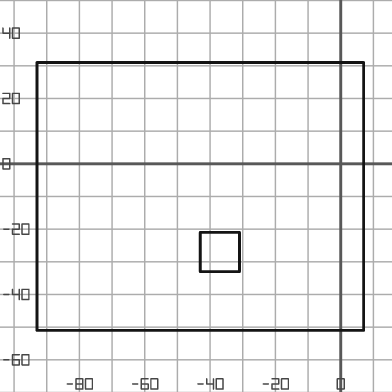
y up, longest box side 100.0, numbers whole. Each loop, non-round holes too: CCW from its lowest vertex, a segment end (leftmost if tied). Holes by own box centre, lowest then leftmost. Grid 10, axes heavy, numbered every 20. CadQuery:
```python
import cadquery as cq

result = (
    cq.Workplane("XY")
    .moveTo(-93.0, -51.0)
    .lineTo(7.0, -51.0)
    .lineTo(7.0, 31.0)
    .lineTo(-93.0, 31.0)
    .close()
    .moveTo(-43.0, -33.0)
    .lineTo(-31.0, -33.0)
    .lineTo(-31.0, -21.0)
    .lineTo(-43.0, -21.0)
    .close()
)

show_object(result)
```